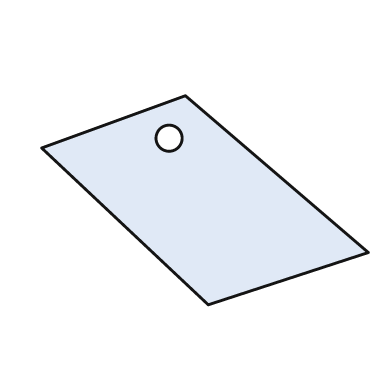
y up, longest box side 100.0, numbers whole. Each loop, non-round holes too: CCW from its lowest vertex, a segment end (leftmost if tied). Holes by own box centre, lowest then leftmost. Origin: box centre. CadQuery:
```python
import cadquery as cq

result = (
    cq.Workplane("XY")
    .moveTo(1.0, -32.0)
    .lineTo(50.0, -16.0)
    .lineTo(-6.0, 32.0)
    .lineTo(-50.0, 16.0)
    .close()
    .moveTo(-11.0, 19.0)
    .circle(4.0)
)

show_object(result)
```